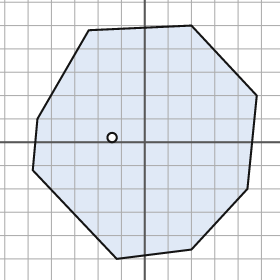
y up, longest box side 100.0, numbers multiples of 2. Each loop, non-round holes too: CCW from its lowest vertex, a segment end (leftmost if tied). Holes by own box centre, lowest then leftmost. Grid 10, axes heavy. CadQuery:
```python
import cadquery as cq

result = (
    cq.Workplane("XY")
    .moveTo(-12.0, -50.0)
    .lineTo(20.0, -46.0)
    .lineTo(44.0, -20.0)
    .lineTo(48.0, 20.0)
    .lineTo(20.0, 50.0)
    .lineTo(-24.0, 48.0)
    .lineTo(-46.0, 10.0)
    .lineTo(-48.0, -12.0)
    .close()
    .moveTo(-14.0, 2.0)
    .circle(2.0)
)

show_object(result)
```